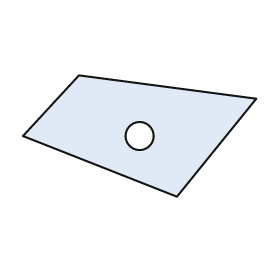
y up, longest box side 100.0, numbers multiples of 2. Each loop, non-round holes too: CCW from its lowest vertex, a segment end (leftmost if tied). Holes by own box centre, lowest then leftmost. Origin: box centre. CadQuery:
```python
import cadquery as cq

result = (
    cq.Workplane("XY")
    .moveTo(16.0, -26.0)
    .lineTo(50.0, 16.0)
    .lineTo(-26.0, 26.0)
    .lineTo(-50.0, 0.0)
    .close()
    .moveTo(0.0, 0.0)
    .circle(6.0)
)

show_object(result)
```